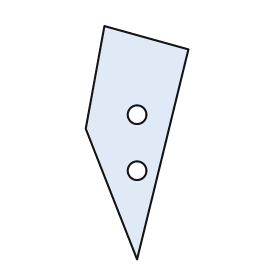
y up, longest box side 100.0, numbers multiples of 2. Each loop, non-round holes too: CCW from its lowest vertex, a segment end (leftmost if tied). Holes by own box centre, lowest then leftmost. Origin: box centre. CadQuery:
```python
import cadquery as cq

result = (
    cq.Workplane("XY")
    .moveTo(0.0, -50.0)
    .lineTo(22.0, 40.0)
    .lineTo(-14.0, 50.0)
    .lineTo(-22.0, 6.0)
    .close()
    .moveTo(0.0, -12.0)
    .circle(4.0)
    .moveTo(0.0, 12.0)
    .circle(4.0)
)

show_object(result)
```